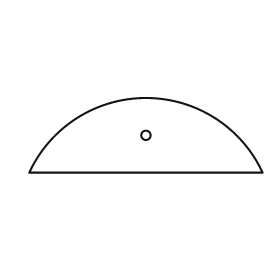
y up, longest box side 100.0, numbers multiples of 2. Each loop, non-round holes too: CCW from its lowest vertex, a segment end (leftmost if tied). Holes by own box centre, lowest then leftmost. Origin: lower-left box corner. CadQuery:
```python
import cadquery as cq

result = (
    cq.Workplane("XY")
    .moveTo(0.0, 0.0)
    .lineTo(100.0, 0.0)
    .threePointArc((50.0, 32.0), (0.0, 0.0))
    .close()
    .moveTo(50.0, 16.0)
    .circle(2.0)
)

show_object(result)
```